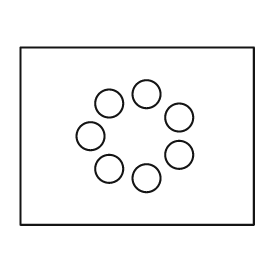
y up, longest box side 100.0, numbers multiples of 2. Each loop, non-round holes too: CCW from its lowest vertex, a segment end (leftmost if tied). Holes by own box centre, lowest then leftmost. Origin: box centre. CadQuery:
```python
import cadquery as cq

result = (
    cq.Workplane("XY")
    .moveTo(-50.0, -38.0)
    .lineTo(50.0, -38.0)
    .lineTo(50.0, 38.0)
    .lineTo(-50.0, 38.0)
    .close()
    .moveTo(4.0, -18.0)
    .circle(6.0)
    .moveTo(-12.0, -14.0)
    .circle(6.0)
    .moveTo(18.0, -8.0)
    .circle(6.0)
    .moveTo(-20.0, 0.0)
    .circle(6.0)
    .moveTo(18.0, 8.0)
    .circle(6.0)
    .moveTo(-12.0, 14.0)
    .circle(6.0)
    .moveTo(4.0, 18.0)
    .circle(6.0)
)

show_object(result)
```